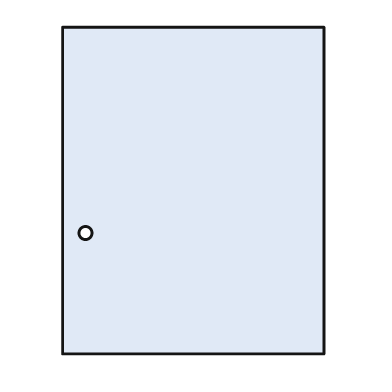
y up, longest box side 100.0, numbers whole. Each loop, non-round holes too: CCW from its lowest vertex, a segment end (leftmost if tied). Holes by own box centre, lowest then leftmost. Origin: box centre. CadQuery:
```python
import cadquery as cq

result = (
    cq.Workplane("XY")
    .moveTo(-40.0, -50.0)
    .lineTo(40.0, -50.0)
    .lineTo(40.0, 50.0)
    .lineTo(-40.0, 50.0)
    .close()
    .moveTo(-33.0, -13.0)
    .circle(2.0)
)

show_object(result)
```